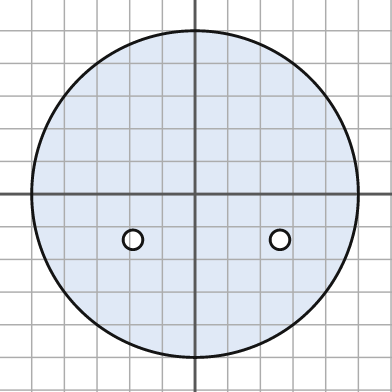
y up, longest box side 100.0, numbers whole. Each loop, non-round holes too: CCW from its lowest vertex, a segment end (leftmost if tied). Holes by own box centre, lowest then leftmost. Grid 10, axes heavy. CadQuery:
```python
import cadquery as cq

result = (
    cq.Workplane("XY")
    .moveTo(0.0, 0.0)
    .circle(50.0)
    .moveTo(-19.0, -14.0)
    .circle(3.0)
    .moveTo(26.0, -14.0)
    .circle(3.0)
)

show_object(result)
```